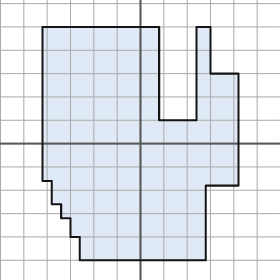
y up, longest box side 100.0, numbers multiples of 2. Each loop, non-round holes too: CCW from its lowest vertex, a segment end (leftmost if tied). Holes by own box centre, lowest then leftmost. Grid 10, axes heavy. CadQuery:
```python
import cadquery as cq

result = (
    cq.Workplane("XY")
    .moveTo(-26.0, -50.0)
    .lineTo(28.0, -50.0)
    .lineTo(28.0, -18.0)
    .lineTo(42.0, -18.0)
    .lineTo(42.0, 30.0)
    .lineTo(30.0, 30.0)
    .lineTo(30.0, 50.0)
    .lineTo(24.0, 50.0)
    .lineTo(24.0, 10.0)
    .lineTo(8.0, 10.0)
    .lineTo(8.0, 50.0)
    .lineTo(-42.0, 50.0)
    .lineTo(-42.0, -16.0)
    .lineTo(-38.0, -16.0)
    .lineTo(-38.0, -26.0)
    .lineTo(-34.0, -26.0)
    .lineTo(-34.0, -32.0)
    .lineTo(-30.0, -32.0)
    .lineTo(-30.0, -40.0)
    .lineTo(-26.0, -40.0)
    .close()
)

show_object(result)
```